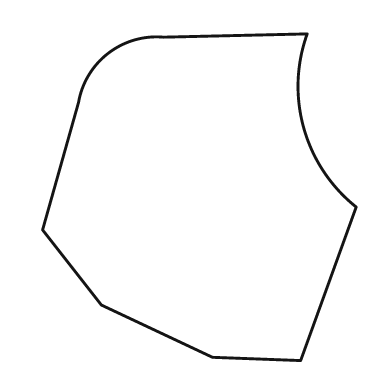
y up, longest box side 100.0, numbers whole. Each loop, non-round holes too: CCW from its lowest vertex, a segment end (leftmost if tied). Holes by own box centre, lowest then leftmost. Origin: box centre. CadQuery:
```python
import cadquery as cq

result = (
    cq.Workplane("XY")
    .moveTo(31.0, -50.0)
    .lineTo(48.0, -3.0)
    .threePointArc((32.0, 21.0), (33.0, 50.0))
    .lineTo(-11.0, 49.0)
    .threePointArc((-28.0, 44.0), (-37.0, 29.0))
    .lineTo(-48.0, -10.0)
    .lineTo(-30.0, -33.0)
    .lineTo(4.0, -49.0)
    .close()
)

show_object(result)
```